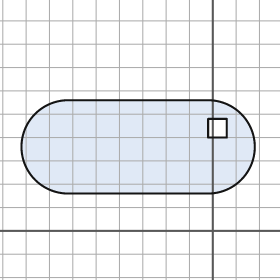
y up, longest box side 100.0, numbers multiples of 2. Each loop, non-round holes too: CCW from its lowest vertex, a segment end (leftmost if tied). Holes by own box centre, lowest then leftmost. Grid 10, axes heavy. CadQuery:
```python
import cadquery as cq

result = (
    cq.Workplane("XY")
    .moveTo(-62.0, 16.0)
    .lineTo(-2.0, 16.0)
    .threePointArc((18.0, 36.0), (-2.0, 56.0))
    .lineTo(-62.0, 56.0)
    .threePointArc((-82.0, 36.0), (-62.0, 16.0))
    .close()
    .moveTo(-2.0, 40.0)
    .lineTo(6.0, 40.0)
    .lineTo(6.0, 48.0)
    .lineTo(-2.0, 48.0)
    .close()
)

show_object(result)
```